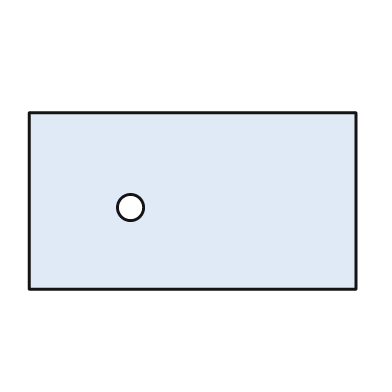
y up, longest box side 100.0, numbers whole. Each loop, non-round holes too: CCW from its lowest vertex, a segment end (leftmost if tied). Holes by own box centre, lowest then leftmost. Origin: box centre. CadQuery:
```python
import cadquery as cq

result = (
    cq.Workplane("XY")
    .moveTo(-50.0, -27.0)
    .lineTo(50.0, -27.0)
    .lineTo(50.0, 27.0)
    .lineTo(-50.0, 27.0)
    .close()
    .moveTo(-19.0, -2.0)
    .circle(4.0)
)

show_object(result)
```